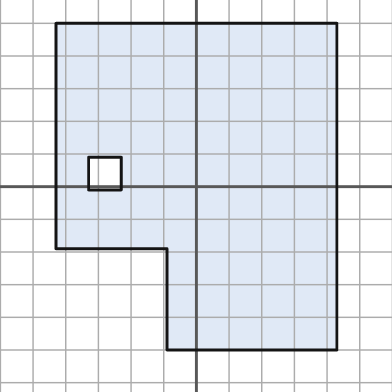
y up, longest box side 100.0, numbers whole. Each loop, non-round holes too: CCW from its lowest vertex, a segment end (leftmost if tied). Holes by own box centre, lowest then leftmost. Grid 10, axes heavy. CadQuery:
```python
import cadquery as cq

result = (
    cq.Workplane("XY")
    .moveTo(-9.0, -50.0)
    .lineTo(43.0, -50.0)
    .lineTo(43.0, 50.0)
    .lineTo(-43.0, 50.0)
    .lineTo(-43.0, -19.0)
    .lineTo(-9.0, -19.0)
    .close()
    .moveTo(-33.0, -1.0)
    .lineTo(-23.0, -1.0)
    .lineTo(-23.0, 9.0)
    .lineTo(-33.0, 9.0)
    .close()
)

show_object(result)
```